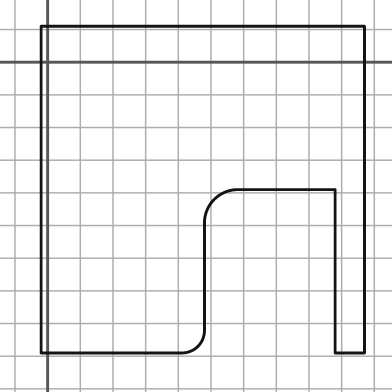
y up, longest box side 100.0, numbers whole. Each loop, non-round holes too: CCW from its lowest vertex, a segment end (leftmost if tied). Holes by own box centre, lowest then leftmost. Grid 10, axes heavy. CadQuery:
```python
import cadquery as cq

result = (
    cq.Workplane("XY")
    .moveTo(-2.0, -89.0)
    .lineTo(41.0, -89.0)
    .threePointArc((46.0, -87.0), (48.0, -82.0))
    .lineTo(48.0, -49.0)
    .threePointArc((51.0, -42.0), (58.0, -39.0))
    .lineTo(88.0, -39.0)
    .lineTo(88.0, -89.0)
    .lineTo(97.0, -89.0)
    .lineTo(97.0, 11.0)
    .lineTo(-2.0, 11.0)
    .close()
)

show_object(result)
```